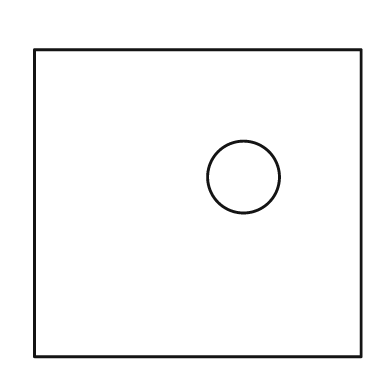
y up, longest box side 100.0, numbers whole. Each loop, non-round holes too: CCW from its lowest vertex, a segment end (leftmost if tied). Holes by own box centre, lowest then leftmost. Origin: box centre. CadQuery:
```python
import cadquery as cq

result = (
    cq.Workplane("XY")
    .moveTo(-50.0, -47.0)
    .lineTo(50.0, -47.0)
    .lineTo(50.0, 47.0)
    .lineTo(-50.0, 47.0)
    .close()
    .moveTo(14.0, 8.0)
    .circle(11.0)
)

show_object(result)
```